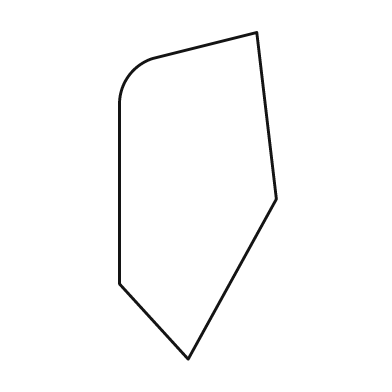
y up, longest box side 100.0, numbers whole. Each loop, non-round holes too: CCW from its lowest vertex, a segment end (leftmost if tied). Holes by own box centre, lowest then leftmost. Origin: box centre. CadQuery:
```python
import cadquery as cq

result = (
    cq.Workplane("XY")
    .moveTo(-3.0, -50.0)
    .lineTo(24.0, -1.0)
    .lineTo(18.0, 50.0)
    .lineTo(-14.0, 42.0)
    .threePointArc((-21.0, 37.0), (-24.0, 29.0))
    .lineTo(-24.0, -27.0)
    .close()
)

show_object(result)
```